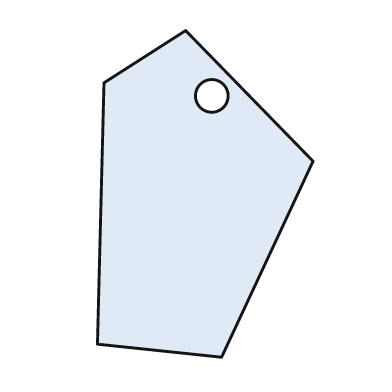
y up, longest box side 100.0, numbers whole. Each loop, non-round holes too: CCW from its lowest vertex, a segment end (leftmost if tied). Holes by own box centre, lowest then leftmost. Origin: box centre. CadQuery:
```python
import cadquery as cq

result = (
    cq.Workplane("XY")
    .moveTo(5.0, -50.0)
    .lineTo(33.0, 10.0)
    .lineTo(-6.0, 50.0)
    .lineTo(-31.0, 34.0)
    .lineTo(-33.0, -46.0)
    .close()
    .moveTo(2.0, 30.0)
    .circle(5.0)
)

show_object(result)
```